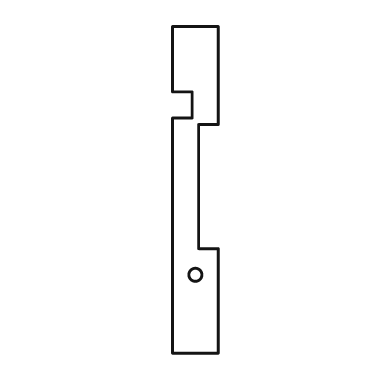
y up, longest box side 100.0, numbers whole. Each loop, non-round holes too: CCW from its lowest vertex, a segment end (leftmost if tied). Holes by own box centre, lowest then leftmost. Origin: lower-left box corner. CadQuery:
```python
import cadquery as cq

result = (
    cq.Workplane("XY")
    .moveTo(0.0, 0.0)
    .lineTo(14.0, 0.0)
    .lineTo(14.0, 32.0)
    .lineTo(8.0, 32.0)
    .lineTo(8.0, 70.0)
    .lineTo(14.0, 70.0)
    .lineTo(14.0, 100.0)
    .lineTo(0.0, 100.0)
    .lineTo(0.0, 80.0)
    .lineTo(6.0, 80.0)
    .lineTo(6.0, 72.0)
    .lineTo(0.0, 72.0)
    .close()
    .moveTo(7.0, 24.0)
    .circle(2.0)
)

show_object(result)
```